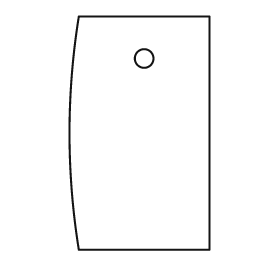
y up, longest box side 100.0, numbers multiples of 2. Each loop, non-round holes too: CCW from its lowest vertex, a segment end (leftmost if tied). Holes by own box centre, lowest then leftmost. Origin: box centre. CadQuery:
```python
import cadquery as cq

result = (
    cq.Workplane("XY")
    .moveTo(-26.0, -50.0)
    .lineTo(30.0, -50.0)
    .lineTo(30.0, 50.0)
    .lineTo(-26.0, 50.0)
    .threePointArc((-30.0, 0.0), (-26.0, -50.0))
    .close()
    .moveTo(2.0, 32.0)
    .circle(4.0)
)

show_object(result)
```